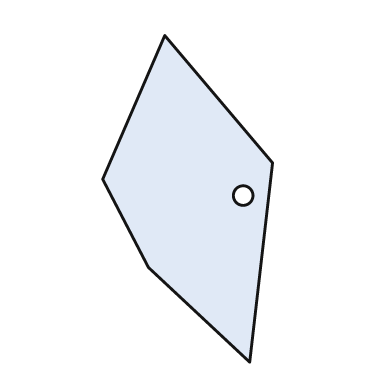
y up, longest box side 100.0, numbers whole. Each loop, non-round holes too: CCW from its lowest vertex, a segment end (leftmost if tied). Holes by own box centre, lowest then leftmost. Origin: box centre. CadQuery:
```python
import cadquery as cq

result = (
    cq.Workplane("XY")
    .moveTo(19.0, -50.0)
    .lineTo(26.0, 11.0)
    .lineTo(-7.0, 50.0)
    .lineTo(-26.0, 6.0)
    .lineTo(-12.0, -21.0)
    .close()
    .moveTo(17.0, 1.0)
    .circle(3.0)
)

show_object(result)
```